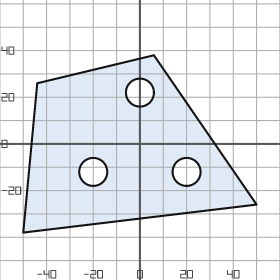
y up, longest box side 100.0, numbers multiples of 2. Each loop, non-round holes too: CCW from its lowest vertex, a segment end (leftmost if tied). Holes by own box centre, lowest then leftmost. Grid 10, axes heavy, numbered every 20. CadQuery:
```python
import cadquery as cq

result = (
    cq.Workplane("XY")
    .moveTo(-50.0, -38.0)
    .lineTo(50.0, -26.0)
    .lineTo(6.0, 38.0)
    .lineTo(-44.0, 26.0)
    .close()
    .moveTo(-20.0, -12.0)
    .circle(6.0)
    .moveTo(20.0, -12.0)
    .circle(6.0)
    .moveTo(0.0, 22.0)
    .circle(6.0)
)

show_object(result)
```